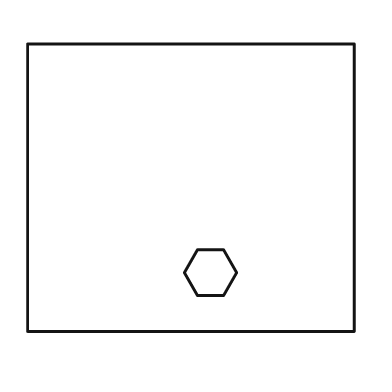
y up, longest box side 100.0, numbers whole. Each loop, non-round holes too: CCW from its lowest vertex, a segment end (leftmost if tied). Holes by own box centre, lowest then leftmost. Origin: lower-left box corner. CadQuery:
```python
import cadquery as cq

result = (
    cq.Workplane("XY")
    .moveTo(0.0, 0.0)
    .lineTo(100.0, 0.0)
    .lineTo(100.0, 88.0)
    .lineTo(0.0, 88.0)
    .close()
    .moveTo(52.0, 11.0)
    .lineTo(60.0, 11.0)
    .lineTo(64.0, 18.0)
    .lineTo(60.0, 25.0)
    .lineTo(52.0, 25.0)
    .lineTo(48.0, 18.0)
    .close()
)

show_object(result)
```